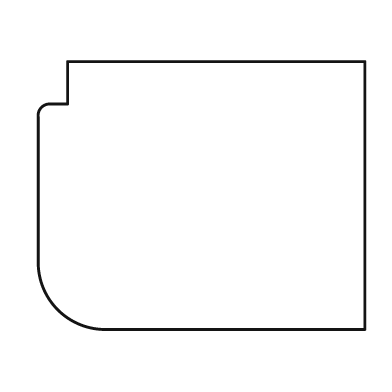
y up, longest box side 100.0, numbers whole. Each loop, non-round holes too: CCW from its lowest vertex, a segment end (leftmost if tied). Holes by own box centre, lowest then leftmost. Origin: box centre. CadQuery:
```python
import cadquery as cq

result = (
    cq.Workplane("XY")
    .moveTo(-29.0, -41.0)
    .lineTo(50.0, -41.0)
    .lineTo(50.0, 41.0)
    .lineTo(-41.0, 41.0)
    .lineTo(-41.0, 28.0)
    .lineTo(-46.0, 28.0)
    .threePointArc((-49.0, 27.0), (-50.0, 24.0))
    .lineTo(-50.0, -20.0)
    .threePointArc((-44.0, -35.0), (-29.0, -41.0))
    .close()
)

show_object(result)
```